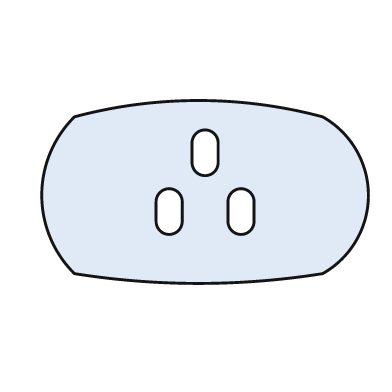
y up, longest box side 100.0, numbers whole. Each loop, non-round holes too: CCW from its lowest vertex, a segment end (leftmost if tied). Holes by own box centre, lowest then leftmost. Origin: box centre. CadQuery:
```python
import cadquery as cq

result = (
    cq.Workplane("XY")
    .moveTo(-40.0, -25.0)
    .threePointArc((-2.0, -28.0), (36.0, -25.0))
    .threePointArc((50.0, -1.0), (36.0, 23.0))
    .threePointArc((-2.0, 28.0), (-40.0, 23.0))
    .threePointArc((-50.0, -1.0), (-40.0, -25.0))
    .close()
    .moveTo(-15.0, -9.0)
    .threePointArc((-11.0, -13.0), (-7.0, -9.0))
    .lineTo(-7.0, -3.0)
    .threePointArc((-11.0, 1.0), (-15.0, -3.0))
    .close()
    .moveTo(7.0, -9.0)
    .threePointArc((11.0, -13.0), (15.0, -9.0))
    .lineTo(15.0, -3.0)
    .threePointArc((11.0, 1.0), (7.0, -3.0))
    .close()
    .moveTo(-4.0, 9.0)
    .threePointArc((0.0, 5.0), (4.0, 9.0))
    .lineTo(4.0, 15.0)
    .threePointArc((0.0, 19.0), (-4.0, 15.0))
    .close()
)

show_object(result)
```